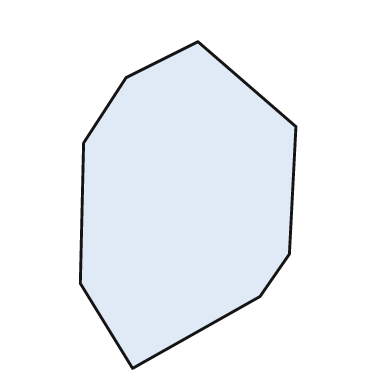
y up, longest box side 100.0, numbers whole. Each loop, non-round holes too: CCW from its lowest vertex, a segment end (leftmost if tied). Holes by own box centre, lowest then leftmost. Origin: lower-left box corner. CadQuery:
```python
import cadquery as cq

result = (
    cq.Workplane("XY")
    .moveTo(16.0, 0.0)
    .lineTo(55.0, 22.0)
    .lineTo(64.0, 35.0)
    .lineTo(66.0, 74.0)
    .lineTo(36.0, 100.0)
    .lineTo(14.0, 89.0)
    .lineTo(1.0, 69.0)
    .lineTo(0.0, 26.0)
    .close()
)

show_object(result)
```